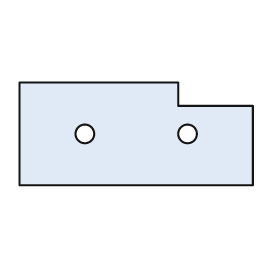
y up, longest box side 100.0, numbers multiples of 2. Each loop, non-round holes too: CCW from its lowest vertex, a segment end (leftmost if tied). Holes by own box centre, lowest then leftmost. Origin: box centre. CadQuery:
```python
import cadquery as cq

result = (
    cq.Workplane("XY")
    .moveTo(-50.0, -22.0)
    .lineTo(50.0, -22.0)
    .lineTo(50.0, 12.0)
    .lineTo(18.0, 12.0)
    .lineTo(18.0, 22.0)
    .lineTo(-50.0, 22.0)
    .close()
    .moveTo(-22.0, 0.0)
    .circle(4.0)
    .moveTo(22.0, 0.0)
    .circle(4.0)
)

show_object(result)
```